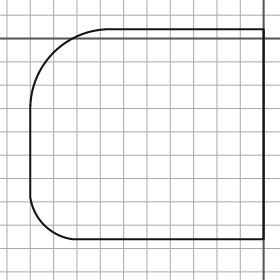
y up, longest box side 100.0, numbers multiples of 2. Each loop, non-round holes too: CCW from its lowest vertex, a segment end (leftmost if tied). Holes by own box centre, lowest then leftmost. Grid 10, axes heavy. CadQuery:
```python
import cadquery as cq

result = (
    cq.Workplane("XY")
    .moveTo(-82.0, -86.0)
    .lineTo(0.0, -86.0)
    .lineTo(0.0, 4.0)
    .lineTo(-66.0, 4.0)
    .threePointArc((-90.0, -6.0), (-100.0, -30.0))
    .lineTo(-100.0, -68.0)
    .threePointArc((-94.0, -80.0), (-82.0, -86.0))
    .close()
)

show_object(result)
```